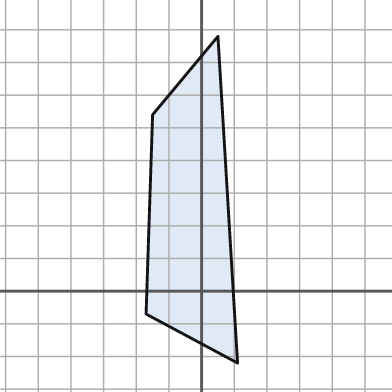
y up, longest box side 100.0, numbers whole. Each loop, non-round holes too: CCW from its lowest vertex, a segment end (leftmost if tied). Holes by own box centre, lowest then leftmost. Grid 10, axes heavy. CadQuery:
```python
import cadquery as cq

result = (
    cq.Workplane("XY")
    .moveTo(11.0, -22.0)
    .lineTo(5.0, 78.0)
    .lineTo(-15.0, 54.0)
    .lineTo(-17.0, -7.0)
    .close()
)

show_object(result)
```